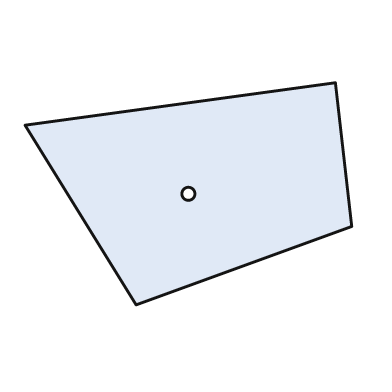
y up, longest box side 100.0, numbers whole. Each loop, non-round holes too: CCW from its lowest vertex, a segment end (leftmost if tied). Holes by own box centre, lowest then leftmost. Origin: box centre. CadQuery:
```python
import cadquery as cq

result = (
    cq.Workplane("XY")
    .moveTo(-16.0, -34.0)
    .lineTo(50.0, -10.0)
    .lineTo(45.0, 34.0)
    .lineTo(-50.0, 21.0)
    .close()
    .moveTo(0.0, 0.0)
    .circle(2.0)
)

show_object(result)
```